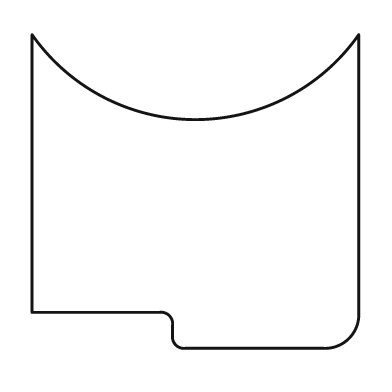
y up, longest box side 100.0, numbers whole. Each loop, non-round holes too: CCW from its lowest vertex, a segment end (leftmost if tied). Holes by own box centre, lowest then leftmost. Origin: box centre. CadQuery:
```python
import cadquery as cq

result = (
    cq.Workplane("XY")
    .moveTo(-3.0, -48.0)
    .lineTo(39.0, -48.0)
    .threePointArc((47.0, -45.0), (50.0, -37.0))
    .lineTo(50.0, 48.0)
    .threePointArc((0.0, 22.0), (-50.0, 48.0))
    .lineTo(-50.0, -37.0)
    .lineTo(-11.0, -37.0)
    .threePointArc((-8.0, -38.0), (-7.0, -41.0))
    .lineTo(-7.0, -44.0)
    .threePointArc((-6.0, -47.0), (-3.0, -48.0))
    .close()
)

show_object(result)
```